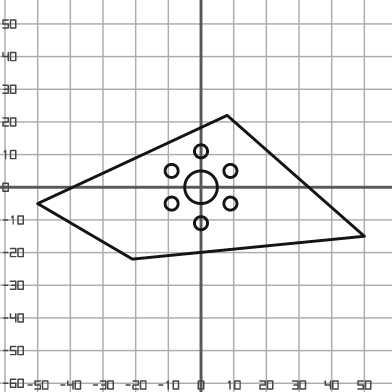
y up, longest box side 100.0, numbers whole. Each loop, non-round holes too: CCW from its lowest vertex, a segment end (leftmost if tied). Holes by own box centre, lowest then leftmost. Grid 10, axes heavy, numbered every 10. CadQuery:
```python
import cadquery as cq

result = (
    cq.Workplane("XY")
    .moveTo(-21.0, -22.0)
    .lineTo(50.0, -15.0)
    .lineTo(8.0, 22.0)
    .lineTo(-50.0, -5.0)
    .close()
    .moveTo(0.0, -11.0)
    .circle(2.0)
    .moveTo(-9.0, -5.0)
    .circle(2.0)
    .moveTo(9.0, -5.0)
    .circle(2.0)
    .moveTo(0.0, 0.0)
    .circle(5.0)
    .moveTo(-9.0, 5.0)
    .circle(2.0)
    .moveTo(9.0, 5.0)
    .circle(2.0)
    .moveTo(0.0, 11.0)
    .circle(2.0)
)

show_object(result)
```